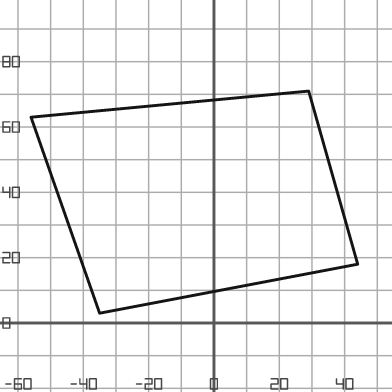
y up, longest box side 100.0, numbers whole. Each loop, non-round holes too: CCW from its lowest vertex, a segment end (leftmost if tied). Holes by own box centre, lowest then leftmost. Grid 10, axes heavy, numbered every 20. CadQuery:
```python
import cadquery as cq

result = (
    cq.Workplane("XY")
    .moveTo(-35.0, 3.0)
    .lineTo(44.0, 18.0)
    .lineTo(29.0, 71.0)
    .lineTo(-56.0, 63.0)
    .close()
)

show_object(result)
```